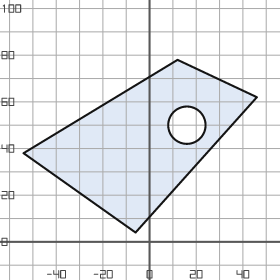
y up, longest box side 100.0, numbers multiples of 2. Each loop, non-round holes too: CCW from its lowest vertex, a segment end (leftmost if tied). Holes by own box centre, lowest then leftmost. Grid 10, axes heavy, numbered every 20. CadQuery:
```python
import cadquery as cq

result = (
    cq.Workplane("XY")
    .moveTo(-6.0, 4.0)
    .lineTo(46.0, 62.0)
    .lineTo(12.0, 78.0)
    .lineTo(-54.0, 38.0)
    .close()
    .moveTo(16.0, 50.0)
    .circle(8.0)
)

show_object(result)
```